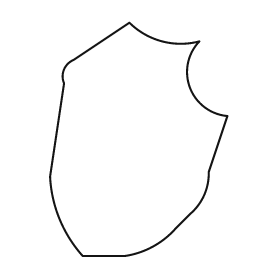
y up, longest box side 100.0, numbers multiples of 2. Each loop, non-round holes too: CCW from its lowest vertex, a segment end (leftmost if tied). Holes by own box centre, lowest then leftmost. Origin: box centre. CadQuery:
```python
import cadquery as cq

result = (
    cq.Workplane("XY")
    .moveTo(-24.0, -50.0)
    .lineTo(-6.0, -50.0)
    .threePointArc((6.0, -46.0), (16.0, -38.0))
    .lineTo(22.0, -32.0)
    .threePointArc((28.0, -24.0), (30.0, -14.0))
    .lineTo(38.0, 10.0)
    .threePointArc((22.0, 22.0), (26.0, 42.0))
    .threePointArc((10.0, 42.0), (-4.0, 50.0))
    .lineTo(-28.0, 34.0)
    .threePointArc((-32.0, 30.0), (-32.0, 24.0))
    .lineTo(-38.0, -16.0)
    .threePointArc((-34.0, -34.0), (-24.0, -50.0))
    .close()
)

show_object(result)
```